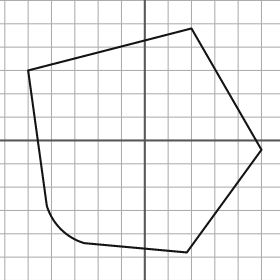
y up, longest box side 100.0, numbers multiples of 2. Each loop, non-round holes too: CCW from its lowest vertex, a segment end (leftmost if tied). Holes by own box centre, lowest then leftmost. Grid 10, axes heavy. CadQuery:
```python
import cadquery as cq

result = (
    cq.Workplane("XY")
    .moveTo(18.0, -48.0)
    .lineTo(50.0, -4.0)
    .lineTo(20.0, 48.0)
    .lineTo(-50.0, 30.0)
    .lineTo(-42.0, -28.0)
    .threePointArc((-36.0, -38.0), (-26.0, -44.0))
    .close()
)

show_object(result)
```